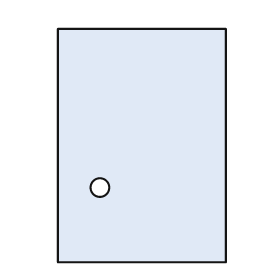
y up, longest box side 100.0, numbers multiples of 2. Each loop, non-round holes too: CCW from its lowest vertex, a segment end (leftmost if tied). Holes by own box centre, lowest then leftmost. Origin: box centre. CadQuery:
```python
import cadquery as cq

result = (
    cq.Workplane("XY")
    .moveTo(-36.0, -50.0)
    .lineTo(36.0, -50.0)
    .lineTo(36.0, 50.0)
    .lineTo(-36.0, 50.0)
    .close()
    .moveTo(-18.0, -18.0)
    .circle(4.0)
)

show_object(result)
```